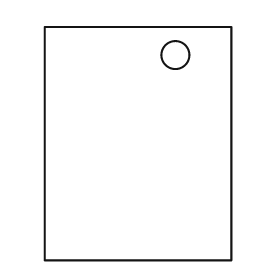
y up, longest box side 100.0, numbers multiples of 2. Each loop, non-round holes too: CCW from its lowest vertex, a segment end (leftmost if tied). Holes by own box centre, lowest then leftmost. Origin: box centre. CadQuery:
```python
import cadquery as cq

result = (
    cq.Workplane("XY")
    .moveTo(-40.0, -50.0)
    .lineTo(40.0, -50.0)
    .lineTo(40.0, 50.0)
    .lineTo(-40.0, 50.0)
    .close()
    .moveTo(16.0, 38.0)
    .circle(6.0)
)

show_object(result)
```